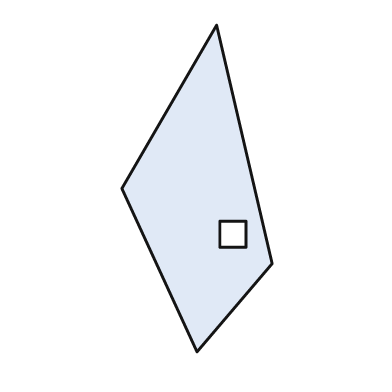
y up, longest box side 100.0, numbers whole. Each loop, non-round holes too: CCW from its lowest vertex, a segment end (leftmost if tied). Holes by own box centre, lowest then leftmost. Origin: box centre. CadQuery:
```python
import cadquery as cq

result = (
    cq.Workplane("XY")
    .moveTo(0.0, -50.0)
    .lineTo(23.0, -23.0)
    .lineTo(6.0, 50.0)
    .lineTo(-23.0, 0.0)
    .close()
    .moveTo(7.0, -18.0)
    .lineTo(15.0, -18.0)
    .lineTo(15.0, -10.0)
    .lineTo(7.0, -10.0)
    .close()
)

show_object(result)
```